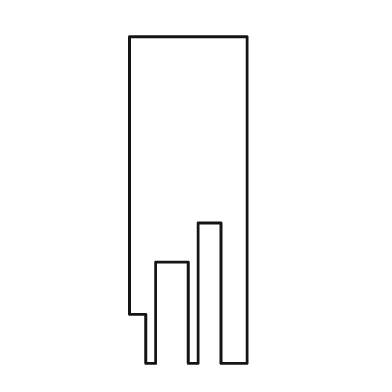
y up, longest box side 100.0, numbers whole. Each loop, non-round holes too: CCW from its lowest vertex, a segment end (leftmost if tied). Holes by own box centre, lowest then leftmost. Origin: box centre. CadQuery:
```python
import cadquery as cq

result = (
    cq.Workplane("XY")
    .moveTo(-13.0, -50.0)
    .lineTo(-10.0, -50.0)
    .lineTo(-10.0, -19.0)
    .lineTo(0.0, -19.0)
    .lineTo(0.0, -50.0)
    .lineTo(3.0, -50.0)
    .lineTo(3.0, -7.0)
    .lineTo(10.0, -7.0)
    .lineTo(10.0, -50.0)
    .lineTo(18.0, -50.0)
    .lineTo(18.0, 50.0)
    .lineTo(-18.0, 50.0)
    .lineTo(-18.0, -35.0)
    .lineTo(-13.0, -35.0)
    .close()
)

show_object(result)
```